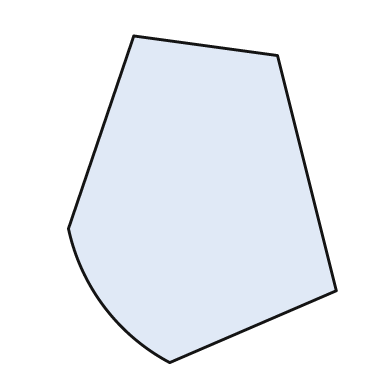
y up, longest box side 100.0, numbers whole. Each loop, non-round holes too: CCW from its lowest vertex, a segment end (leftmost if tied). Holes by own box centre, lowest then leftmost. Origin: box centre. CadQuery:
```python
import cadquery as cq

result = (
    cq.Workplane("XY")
    .moveTo(-10.0, -50.0)
    .lineTo(41.0, -28.0)
    .lineTo(23.0, 44.0)
    .lineTo(-21.0, 50.0)
    .lineTo(-41.0, -9.0)
    .threePointArc((-30.0, -33.0), (-10.0, -50.0))
    .close()
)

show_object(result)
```